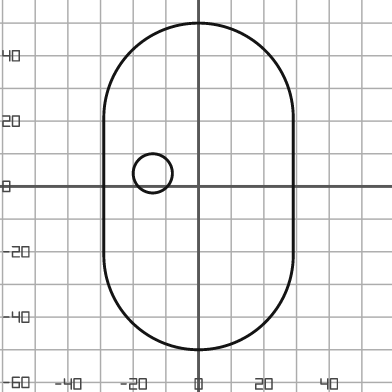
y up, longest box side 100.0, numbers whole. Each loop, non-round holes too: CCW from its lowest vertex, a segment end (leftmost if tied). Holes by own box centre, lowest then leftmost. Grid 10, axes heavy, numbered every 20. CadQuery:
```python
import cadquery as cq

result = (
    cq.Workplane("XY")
    .moveTo(-29.0, -21.0)
    .threePointArc((0.0, -50.0), (29.0, -21.0))
    .lineTo(29.0, 21.0)
    .threePointArc((0.0, 50.0), (-29.0, 21.0))
    .close()
    .moveTo(-14.0, 4.0)
    .circle(6.0)
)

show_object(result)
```